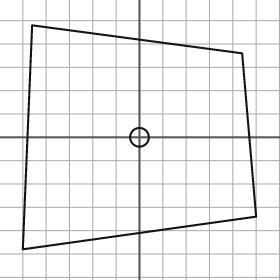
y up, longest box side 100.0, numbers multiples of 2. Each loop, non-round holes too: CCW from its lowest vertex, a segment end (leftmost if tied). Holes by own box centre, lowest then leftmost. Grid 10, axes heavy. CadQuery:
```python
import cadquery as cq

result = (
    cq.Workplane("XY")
    .moveTo(-50.0, -48.0)
    .lineTo(50.0, -34.0)
    .lineTo(44.0, 36.0)
    .lineTo(-46.0, 48.0)
    .close()
    .moveTo(0.0, 0.0)
    .circle(4.0)
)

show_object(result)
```